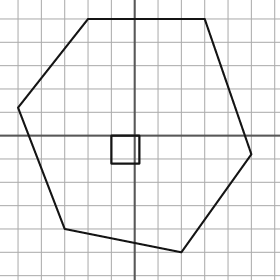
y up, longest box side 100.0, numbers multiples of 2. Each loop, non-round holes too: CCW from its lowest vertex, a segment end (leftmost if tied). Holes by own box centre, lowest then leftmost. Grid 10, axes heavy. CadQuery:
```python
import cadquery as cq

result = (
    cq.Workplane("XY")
    .moveTo(20.0, -50.0)
    .lineTo(50.0, -8.0)
    .lineTo(30.0, 50.0)
    .lineTo(-20.0, 50.0)
    .lineTo(-50.0, 12.0)
    .lineTo(-30.0, -40.0)
    .close()
    .moveTo(-10.0, -12.0)
    .lineTo(2.0, -12.0)
    .lineTo(2.0, 0.0)
    .lineTo(-10.0, 0.0)
    .close()
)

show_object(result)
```